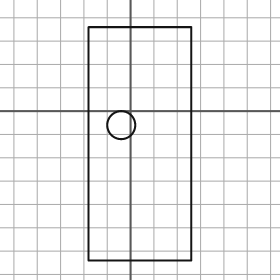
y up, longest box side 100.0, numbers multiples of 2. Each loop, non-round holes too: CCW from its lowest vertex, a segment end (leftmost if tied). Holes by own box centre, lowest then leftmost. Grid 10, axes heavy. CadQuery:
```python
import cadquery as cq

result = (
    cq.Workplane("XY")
    .moveTo(-18.0, -64.0)
    .lineTo(26.0, -64.0)
    .lineTo(26.0, 36.0)
    .lineTo(-18.0, 36.0)
    .close()
    .moveTo(-4.0, -6.0)
    .circle(6.0)
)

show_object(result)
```